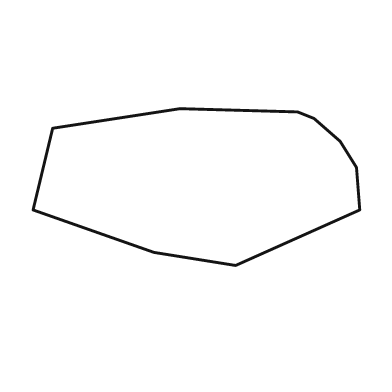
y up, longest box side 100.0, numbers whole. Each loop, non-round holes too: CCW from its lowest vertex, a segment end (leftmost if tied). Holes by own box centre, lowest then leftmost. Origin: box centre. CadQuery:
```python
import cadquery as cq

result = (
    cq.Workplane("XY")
    .moveTo(12.0, -24.0)
    .lineTo(50.0, -7.0)
    .lineTo(49.0, 6.0)
    .lineTo(44.0, 14.0)
    .lineTo(36.0, 21.0)
    .lineTo(31.0, 23.0)
    .lineTo(-5.0, 24.0)
    .lineTo(-44.0, 18.0)
    .lineTo(-50.0, -7.0)
    .lineTo(-13.0, -20.0)
    .close()
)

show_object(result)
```